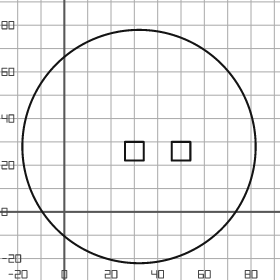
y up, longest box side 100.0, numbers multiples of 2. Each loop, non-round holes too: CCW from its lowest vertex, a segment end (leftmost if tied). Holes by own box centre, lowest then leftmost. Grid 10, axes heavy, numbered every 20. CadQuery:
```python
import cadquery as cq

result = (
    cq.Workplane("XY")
    .moveTo(32.0, 28.0)
    .circle(50.0)
    .moveTo(26.0, 22.0)
    .lineTo(34.0, 22.0)
    .lineTo(34.0, 30.0)
    .lineTo(26.0, 30.0)
    .close()
    .moveTo(46.0, 22.0)
    .lineTo(54.0, 22.0)
    .lineTo(54.0, 30.0)
    .lineTo(46.0, 30.0)
    .close()
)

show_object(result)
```